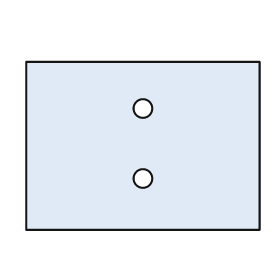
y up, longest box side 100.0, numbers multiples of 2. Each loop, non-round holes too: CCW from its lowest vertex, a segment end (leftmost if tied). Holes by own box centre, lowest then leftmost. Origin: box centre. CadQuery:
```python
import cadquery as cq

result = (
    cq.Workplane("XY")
    .moveTo(-50.0, -36.0)
    .lineTo(50.0, -36.0)
    .lineTo(50.0, 36.0)
    .lineTo(-50.0, 36.0)
    .close()
    .moveTo(0.0, -14.0)
    .circle(4.0)
    .moveTo(0.0, 16.0)
    .circle(4.0)
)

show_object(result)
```